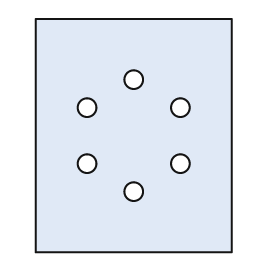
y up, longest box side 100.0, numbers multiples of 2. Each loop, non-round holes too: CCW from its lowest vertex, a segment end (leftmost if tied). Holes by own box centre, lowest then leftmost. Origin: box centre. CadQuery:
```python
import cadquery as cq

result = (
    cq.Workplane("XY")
    .moveTo(-42.0, -50.0)
    .lineTo(42.0, -50.0)
    .lineTo(42.0, 50.0)
    .lineTo(-42.0, 50.0)
    .close()
    .moveTo(0.0, -24.0)
    .circle(4.0)
    .moveTo(-20.0, -12.0)
    .circle(4.0)
    .moveTo(20.0, -12.0)
    .circle(4.0)
    .moveTo(-20.0, 12.0)
    .circle(4.0)
    .moveTo(20.0, 12.0)
    .circle(4.0)
    .moveTo(0.0, 24.0)
    .circle(4.0)
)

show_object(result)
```